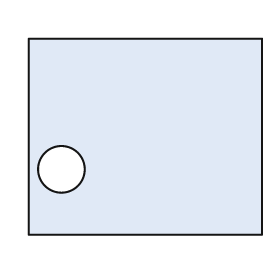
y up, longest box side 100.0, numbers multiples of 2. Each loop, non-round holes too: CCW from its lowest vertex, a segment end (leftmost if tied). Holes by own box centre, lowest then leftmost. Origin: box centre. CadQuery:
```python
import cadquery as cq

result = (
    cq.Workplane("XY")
    .moveTo(-50.0, -42.0)
    .lineTo(50.0, -42.0)
    .lineTo(50.0, 42.0)
    .lineTo(-50.0, 42.0)
    .close()
    .moveTo(-36.0, -14.0)
    .circle(10.0)
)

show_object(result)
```